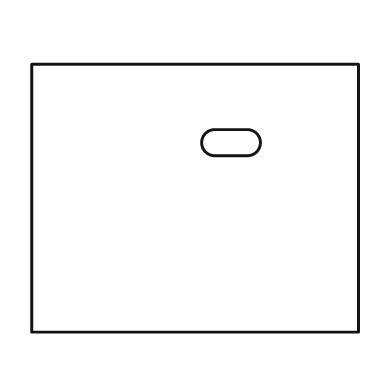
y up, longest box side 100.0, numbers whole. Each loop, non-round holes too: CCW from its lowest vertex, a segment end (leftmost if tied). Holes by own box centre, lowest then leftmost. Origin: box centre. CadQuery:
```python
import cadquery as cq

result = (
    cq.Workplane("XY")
    .moveTo(-50.0, -41.0)
    .lineTo(50.0, -41.0)
    .lineTo(50.0, 41.0)
    .lineTo(-50.0, 41.0)
    .close()
    .moveTo(6.0, 13.0)
    .lineTo(16.0, 13.0)
    .threePointArc((20.0, 17.0), (16.0, 21.0))
    .lineTo(6.0, 21.0)
    .threePointArc((2.0, 17.0), (6.0, 13.0))
    .close()
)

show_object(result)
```